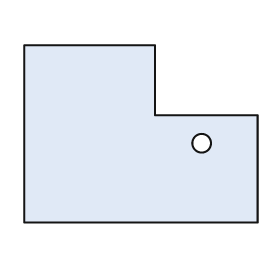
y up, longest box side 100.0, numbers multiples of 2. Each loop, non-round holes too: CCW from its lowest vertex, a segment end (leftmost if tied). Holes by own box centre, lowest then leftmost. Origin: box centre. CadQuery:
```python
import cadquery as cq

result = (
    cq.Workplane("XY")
    .moveTo(-50.0, -38.0)
    .lineTo(50.0, -38.0)
    .lineTo(50.0, 8.0)
    .lineTo(6.0, 8.0)
    .lineTo(6.0, 38.0)
    .lineTo(-50.0, 38.0)
    .close()
    .moveTo(26.0, -4.0)
    .circle(4.0)
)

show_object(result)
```